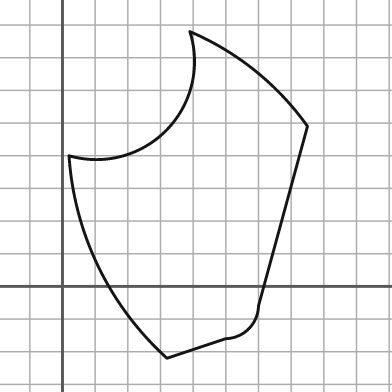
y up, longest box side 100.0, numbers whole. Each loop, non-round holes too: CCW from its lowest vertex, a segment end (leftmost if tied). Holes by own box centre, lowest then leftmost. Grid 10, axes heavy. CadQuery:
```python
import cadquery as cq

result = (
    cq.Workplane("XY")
    .moveTo(32.0, -22.0)
    .lineTo(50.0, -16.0)
    .threePointArc((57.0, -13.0), (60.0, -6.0))
    .lineTo(75.0, 49.0)
    .threePointArc((59.0, 66.0), (39.0, 78.0))
    .threePointArc((32.0, 48.0), (2.0, 40.0))
    .threePointArc((11.0, 6.0), (32.0, -22.0))
    .close()
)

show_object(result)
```